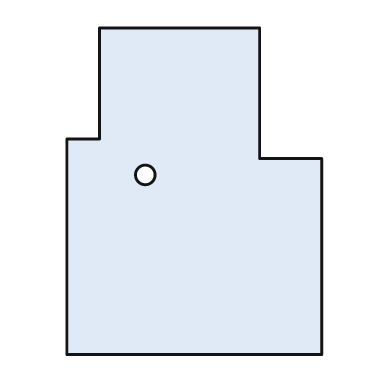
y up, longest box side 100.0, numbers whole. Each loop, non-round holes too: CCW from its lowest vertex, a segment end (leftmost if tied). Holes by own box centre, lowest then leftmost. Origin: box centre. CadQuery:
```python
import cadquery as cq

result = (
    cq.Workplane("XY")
    .moveTo(-39.0, -50.0)
    .lineTo(39.0, -50.0)
    .lineTo(39.0, 10.0)
    .lineTo(20.0, 10.0)
    .lineTo(20.0, 50.0)
    .lineTo(-29.0, 50.0)
    .lineTo(-29.0, 16.0)
    .lineTo(-39.0, 16.0)
    .close()
    .moveTo(-15.0, 5.0)
    .circle(3.0)
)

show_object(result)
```